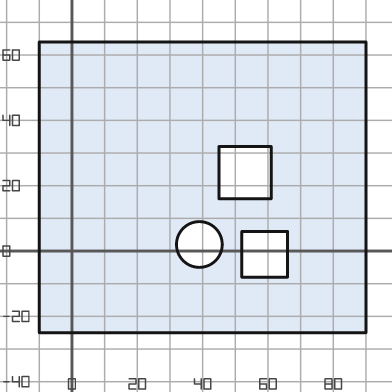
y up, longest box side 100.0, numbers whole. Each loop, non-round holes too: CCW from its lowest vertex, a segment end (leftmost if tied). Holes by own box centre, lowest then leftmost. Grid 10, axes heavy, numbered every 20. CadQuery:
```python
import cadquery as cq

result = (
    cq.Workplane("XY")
    .moveTo(-10.0, -25.0)
    .lineTo(90.0, -25.0)
    .lineTo(90.0, 64.0)
    .lineTo(-10.0, 64.0)
    .close()
    .moveTo(52.0, -8.0)
    .lineTo(66.0, -8.0)
    .lineTo(66.0, 6.0)
    .lineTo(52.0, 6.0)
    .close()
    .moveTo(39.0, 2.0)
    .circle(7.0)
    .moveTo(45.0, 16.0)
    .lineTo(61.0, 16.0)
    .lineTo(61.0, 32.0)
    .lineTo(45.0, 32.0)
    .close()
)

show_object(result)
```